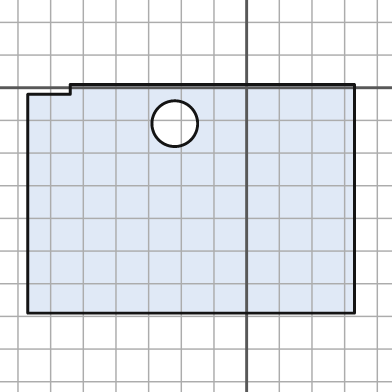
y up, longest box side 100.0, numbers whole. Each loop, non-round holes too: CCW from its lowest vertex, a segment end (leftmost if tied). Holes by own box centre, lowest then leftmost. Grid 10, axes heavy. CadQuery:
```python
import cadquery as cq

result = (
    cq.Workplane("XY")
    .moveTo(-67.0, -69.0)
    .lineTo(33.0, -69.0)
    .lineTo(33.0, 1.0)
    .lineTo(-54.0, 1.0)
    .lineTo(-54.0, -2.0)
    .lineTo(-67.0, -2.0)
    .close()
    .moveTo(-22.0, -11.0)
    .circle(7.0)
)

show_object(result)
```